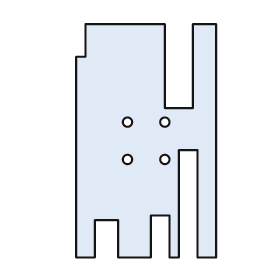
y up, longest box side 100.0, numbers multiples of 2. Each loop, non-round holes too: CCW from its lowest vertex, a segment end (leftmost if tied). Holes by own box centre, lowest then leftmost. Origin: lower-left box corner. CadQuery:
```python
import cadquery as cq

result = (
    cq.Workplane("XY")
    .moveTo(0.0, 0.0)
    .lineTo(8.0, 0.0)
    .lineTo(8.0, 16.0)
    .lineTo(18.0, 16.0)
    .lineTo(18.0, 0.0)
    .lineTo(32.0, 0.0)
    .lineTo(32.0, 18.0)
    .lineTo(40.0, 18.0)
    .lineTo(40.0, 0.0)
    .lineTo(44.0, 0.0)
    .lineTo(44.0, 46.0)
    .lineTo(52.0, 46.0)
    .lineTo(52.0, 0.0)
    .lineTo(60.0, 0.0)
    .lineTo(60.0, 100.0)
    .lineTo(50.0, 100.0)
    .lineTo(50.0, 64.0)
    .lineTo(38.0, 64.0)
    .lineTo(38.0, 100.0)
    .lineTo(4.0, 100.0)
    .lineTo(4.0, 86.0)
    .lineTo(0.0, 86.0)
    .close()
    .moveTo(22.0, 42.0)
    .circle(2.0)
    .moveTo(38.0, 42.0)
    .circle(2.0)
    .moveTo(22.0, 58.0)
    .circle(2.0)
    .moveTo(38.0, 58.0)
    .circle(2.0)
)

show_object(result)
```